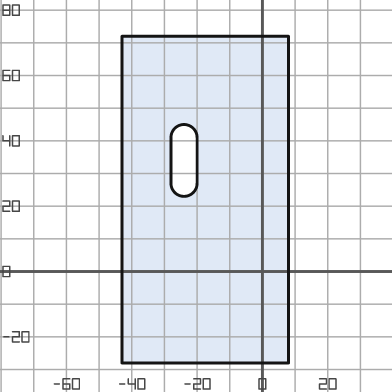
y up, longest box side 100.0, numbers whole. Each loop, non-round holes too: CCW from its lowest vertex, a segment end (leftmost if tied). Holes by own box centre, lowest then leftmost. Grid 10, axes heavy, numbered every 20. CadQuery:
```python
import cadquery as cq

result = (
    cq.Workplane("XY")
    .moveTo(-43.0, -28.0)
    .lineTo(8.0, -28.0)
    .lineTo(8.0, 72.0)
    .lineTo(-43.0, 72.0)
    .close()
    .moveTo(-28.0, 27.0)
    .threePointArc((-24.0, 23.0), (-20.0, 27.0))
    .lineTo(-20.0, 41.0)
    .threePointArc((-24.0, 45.0), (-28.0, 41.0))
    .close()
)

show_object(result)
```